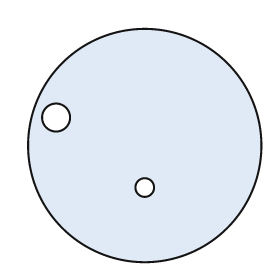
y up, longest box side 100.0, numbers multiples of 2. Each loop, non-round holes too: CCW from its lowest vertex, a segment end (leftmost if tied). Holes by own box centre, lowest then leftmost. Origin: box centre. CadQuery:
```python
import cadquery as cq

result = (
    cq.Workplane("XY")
    .moveTo(0.0, 0.0)
    .circle(50.0)
    .moveTo(0.0, -18.0)
    .circle(4.0)
    .moveTo(-38.0, 12.0)
    .circle(6.0)
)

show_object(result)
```